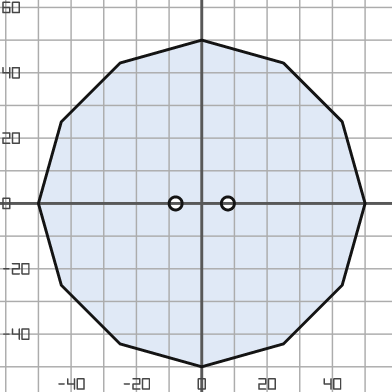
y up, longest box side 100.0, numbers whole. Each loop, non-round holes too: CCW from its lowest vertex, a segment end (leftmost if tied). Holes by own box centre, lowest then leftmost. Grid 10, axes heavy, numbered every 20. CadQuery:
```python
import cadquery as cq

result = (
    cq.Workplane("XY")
    .moveTo(0.0, -50.0)
    .lineTo(25.0, -43.0)
    .lineTo(43.0, -25.0)
    .lineTo(50.0, 0.0)
    .lineTo(43.0, 25.0)
    .lineTo(25.0, 43.0)
    .lineTo(0.0, 50.0)
    .lineTo(-25.0, 43.0)
    .lineTo(-43.0, 25.0)
    .lineTo(-50.0, 0.0)
    .lineTo(-43.0, -25.0)
    .lineTo(-25.0, -43.0)
    .close()
    .moveTo(-8.0, 0.0)
    .circle(2.0)
    .moveTo(8.0, 0.0)
    .circle(2.0)
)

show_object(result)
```